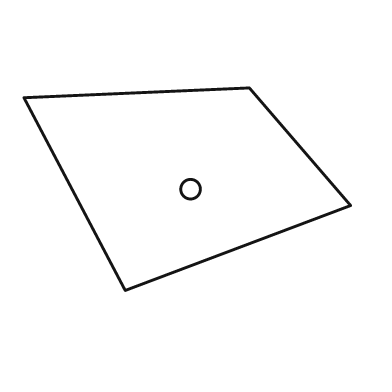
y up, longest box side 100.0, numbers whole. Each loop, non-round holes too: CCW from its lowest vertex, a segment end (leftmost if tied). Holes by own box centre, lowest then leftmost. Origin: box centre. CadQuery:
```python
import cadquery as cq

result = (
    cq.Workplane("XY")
    .moveTo(-19.0, -31.0)
    .lineTo(50.0, -5.0)
    .lineTo(19.0, 31.0)
    .lineTo(-50.0, 28.0)
    .close()
    .moveTo(1.0, 0.0)
    .circle(3.0)
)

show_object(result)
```